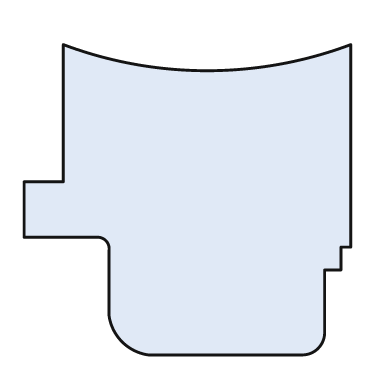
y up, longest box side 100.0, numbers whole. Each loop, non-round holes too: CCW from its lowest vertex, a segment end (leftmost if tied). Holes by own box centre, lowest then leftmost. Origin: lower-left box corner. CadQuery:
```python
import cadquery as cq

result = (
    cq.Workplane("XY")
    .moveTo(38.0, 0.0)
    .lineTo(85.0, 0.0)
    .threePointArc((90.0, 2.0), (92.0, 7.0))
    .lineTo(92.0, 26.0)
    .lineTo(97.0, 26.0)
    .lineTo(97.0, 33.0)
    .lineTo(100.0, 33.0)
    .lineTo(100.0, 95.0)
    .threePointArc((56.0, 87.0), (12.0, 95.0))
    .lineTo(12.0, 53.0)
    .lineTo(0.0, 53.0)
    .lineTo(0.0, 36.0)
    .lineTo(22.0, 36.0)
    .threePointArc((25.0, 35.0), (26.0, 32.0))
    .lineTo(26.0, 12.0)
    .threePointArc((30.0, 4.0), (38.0, 0.0))
    .close()
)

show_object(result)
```